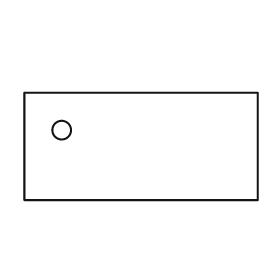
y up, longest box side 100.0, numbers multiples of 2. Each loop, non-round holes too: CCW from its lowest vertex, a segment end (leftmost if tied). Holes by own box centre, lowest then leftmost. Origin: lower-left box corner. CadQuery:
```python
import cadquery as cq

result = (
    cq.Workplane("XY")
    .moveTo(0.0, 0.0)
    .lineTo(100.0, 0.0)
    .lineTo(100.0, 46.0)
    .lineTo(0.0, 46.0)
    .close()
    .moveTo(16.0, 30.0)
    .circle(4.0)
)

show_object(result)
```